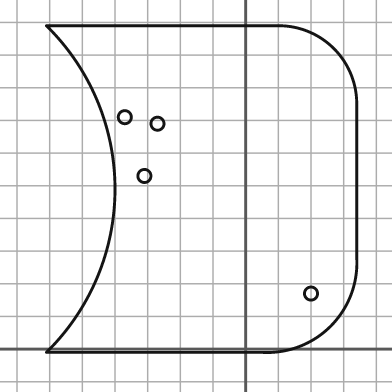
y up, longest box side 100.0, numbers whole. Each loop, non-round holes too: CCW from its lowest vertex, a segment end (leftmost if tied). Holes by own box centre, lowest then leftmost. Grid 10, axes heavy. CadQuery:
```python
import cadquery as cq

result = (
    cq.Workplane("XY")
    .moveTo(-61.0, -1.0)
    .lineTo(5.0, -1.0)
    .threePointArc((26.0, 7.0), (34.0, 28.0))
    .lineTo(34.0, 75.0)
    .threePointArc((27.0, 92.0), (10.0, 99.0))
    .lineTo(-61.0, 99.0)
    .threePointArc((-40.0, 49.0), (-61.0, -1.0))
    .close()
    .moveTo(20.0, 17.0)
    .circle(2.0)
    .moveTo(-31.0, 53.0)
    .circle(2.0)
    .moveTo(-27.0, 69.0)
    .circle(2.0)
    .moveTo(-37.0, 71.0)
    .circle(2.0)
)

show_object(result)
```